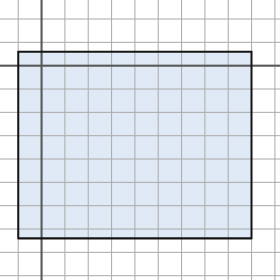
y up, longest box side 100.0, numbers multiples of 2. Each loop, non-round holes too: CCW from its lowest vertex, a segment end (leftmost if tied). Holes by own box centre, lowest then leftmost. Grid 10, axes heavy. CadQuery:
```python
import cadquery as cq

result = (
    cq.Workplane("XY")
    .moveTo(-10.0, -74.0)
    .lineTo(90.0, -74.0)
    .lineTo(90.0, 6.0)
    .lineTo(-10.0, 6.0)
    .close()
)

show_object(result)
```